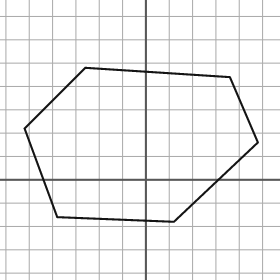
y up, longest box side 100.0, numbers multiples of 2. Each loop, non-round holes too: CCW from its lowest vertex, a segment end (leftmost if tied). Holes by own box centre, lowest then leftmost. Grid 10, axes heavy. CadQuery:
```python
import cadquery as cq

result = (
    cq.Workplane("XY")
    .moveTo(12.0, -18.0)
    .lineTo(48.0, 16.0)
    .lineTo(36.0, 44.0)
    .lineTo(-26.0, 48.0)
    .lineTo(-52.0, 22.0)
    .lineTo(-38.0, -16.0)
    .close()
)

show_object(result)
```